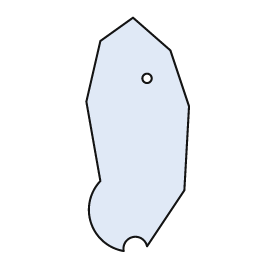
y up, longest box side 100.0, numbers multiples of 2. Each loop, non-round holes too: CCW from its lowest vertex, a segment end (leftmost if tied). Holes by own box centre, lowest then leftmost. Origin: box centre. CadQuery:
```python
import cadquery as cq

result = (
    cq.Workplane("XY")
    .moveTo(-6.0, -50.0)
    .threePointArc((-2.0, -44.0), (4.0, -48.0))
    .lineTo(20.0, -24.0)
    .lineTo(22.0, 12.0)
    .lineTo(14.0, 36.0)
    .lineTo(-2.0, 50.0)
    .lineTo(-16.0, 40.0)
    .lineTo(-22.0, 14.0)
    .lineTo(-16.0, -20.0)
    .threePointArc((-20.0, -38.0), (-6.0, -50.0))
    .close()
    .moveTo(4.0, 24.0)
    .circle(2.0)
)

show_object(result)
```